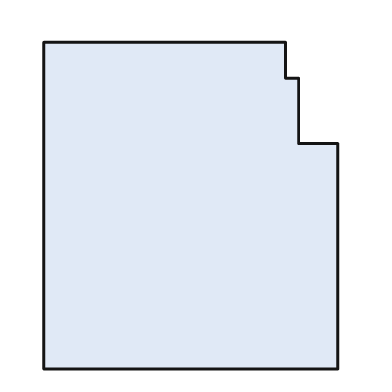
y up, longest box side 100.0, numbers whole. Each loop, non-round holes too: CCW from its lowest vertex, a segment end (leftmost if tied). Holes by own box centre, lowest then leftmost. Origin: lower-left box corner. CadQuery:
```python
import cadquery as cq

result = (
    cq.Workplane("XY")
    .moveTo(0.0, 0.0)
    .lineTo(90.0, 0.0)
    .lineTo(90.0, 69.0)
    .lineTo(78.0, 69.0)
    .lineTo(78.0, 89.0)
    .lineTo(74.0, 89.0)
    .lineTo(74.0, 100.0)
    .lineTo(0.0, 100.0)
    .close()
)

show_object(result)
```